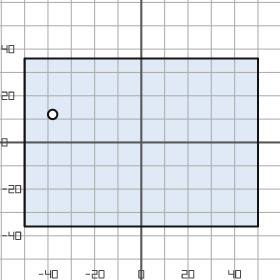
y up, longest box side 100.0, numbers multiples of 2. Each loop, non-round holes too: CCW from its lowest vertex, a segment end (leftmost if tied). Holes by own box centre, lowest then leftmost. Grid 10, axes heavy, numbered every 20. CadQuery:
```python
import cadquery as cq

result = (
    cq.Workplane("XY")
    .moveTo(-50.0, -36.0)
    .lineTo(50.0, -36.0)
    .lineTo(50.0, 36.0)
    .lineTo(-50.0, 36.0)
    .close()
    .moveTo(-38.0, 12.0)
    .circle(2.0)
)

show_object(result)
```